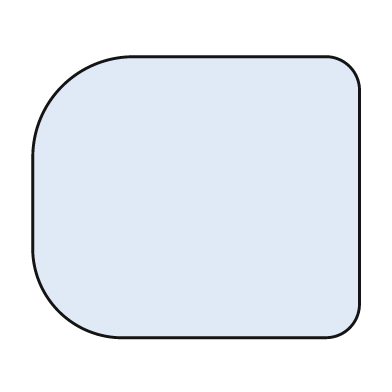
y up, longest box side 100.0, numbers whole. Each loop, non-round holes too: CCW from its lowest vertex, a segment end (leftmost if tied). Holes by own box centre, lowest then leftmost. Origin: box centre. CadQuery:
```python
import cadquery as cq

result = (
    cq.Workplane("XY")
    .moveTo(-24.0, -43.0)
    .lineTo(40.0, -43.0)
    .threePointArc((47.0, -40.0), (50.0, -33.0))
    .lineTo(50.0, 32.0)
    .threePointArc((47.0, 40.0), (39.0, 43.0))
    .lineTo(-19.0, 43.0)
    .threePointArc((-41.0, 34.0), (-50.0, 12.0))
    .lineTo(-50.0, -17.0)
    .threePointArc((-42.0, -35.0), (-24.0, -43.0))
    .close()
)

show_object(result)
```